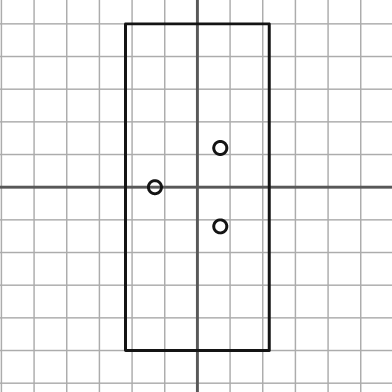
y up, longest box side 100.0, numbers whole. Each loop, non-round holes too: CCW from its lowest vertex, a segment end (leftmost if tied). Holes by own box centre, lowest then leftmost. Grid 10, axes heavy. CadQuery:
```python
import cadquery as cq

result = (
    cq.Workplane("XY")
    .moveTo(-22.0, -50.0)
    .lineTo(22.0, -50.0)
    .lineTo(22.0, 50.0)
    .lineTo(-22.0, 50.0)
    .close()
    .moveTo(7.0, -12.0)
    .circle(2.0)
    .moveTo(-13.0, 0.0)
    .circle(2.0)
    .moveTo(7.0, 12.0)
    .circle(2.0)
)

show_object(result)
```